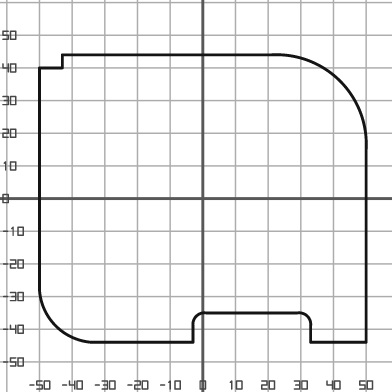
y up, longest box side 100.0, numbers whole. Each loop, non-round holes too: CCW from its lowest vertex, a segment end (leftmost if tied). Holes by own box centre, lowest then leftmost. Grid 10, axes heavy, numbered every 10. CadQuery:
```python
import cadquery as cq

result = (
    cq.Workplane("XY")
    .moveTo(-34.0, -44.0)
    .lineTo(-3.0, -44.0)
    .lineTo(-3.0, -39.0)
    .threePointArc((-2.0, -36.0), (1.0, -35.0))
    .lineTo(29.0, -35.0)
    .threePointArc((32.0, -36.0), (33.0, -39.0))
    .lineTo(33.0, -44.0)
    .lineTo(50.0, -44.0)
    .lineTo(50.0, 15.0)
    .threePointArc((42.0, 36.0), (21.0, 44.0))
    .lineTo(-43.0, 44.0)
    .lineTo(-43.0, 40.0)
    .lineTo(-50.0, 40.0)
    .lineTo(-50.0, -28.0)
    .threePointArc((-45.0, -39.0), (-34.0, -44.0))
    .close()
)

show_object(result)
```